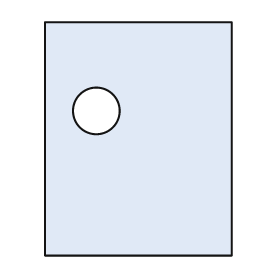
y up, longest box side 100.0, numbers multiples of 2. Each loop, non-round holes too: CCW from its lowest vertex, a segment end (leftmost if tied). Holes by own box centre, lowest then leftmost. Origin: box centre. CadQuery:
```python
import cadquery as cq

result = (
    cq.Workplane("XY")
    .moveTo(-40.0, -50.0)
    .lineTo(40.0, -50.0)
    .lineTo(40.0, 50.0)
    .lineTo(-40.0, 50.0)
    .close()
    .moveTo(-18.0, 12.0)
    .circle(10.0)
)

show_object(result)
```